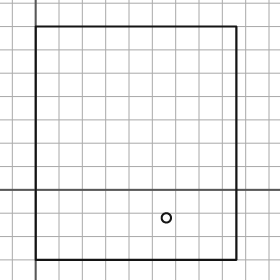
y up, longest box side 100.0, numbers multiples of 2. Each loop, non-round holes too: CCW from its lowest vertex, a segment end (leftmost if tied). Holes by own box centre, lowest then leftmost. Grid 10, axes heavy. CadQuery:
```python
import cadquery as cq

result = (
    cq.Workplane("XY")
    .moveTo(0.0, -30.0)
    .lineTo(86.0, -30.0)
    .lineTo(86.0, 70.0)
    .lineTo(0.0, 70.0)
    .close()
    .moveTo(56.0, -12.0)
    .circle(2.0)
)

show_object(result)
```